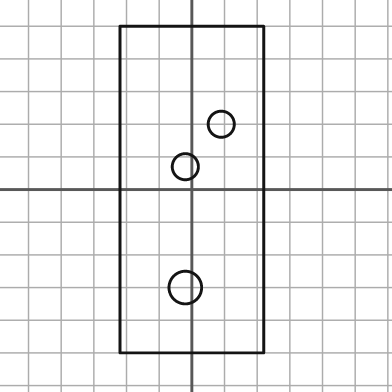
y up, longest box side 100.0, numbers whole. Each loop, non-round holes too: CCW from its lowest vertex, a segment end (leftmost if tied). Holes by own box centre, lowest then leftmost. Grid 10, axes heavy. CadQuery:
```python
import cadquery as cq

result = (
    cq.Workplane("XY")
    .moveTo(-22.0, -50.0)
    .lineTo(22.0, -50.0)
    .lineTo(22.0, 50.0)
    .lineTo(-22.0, 50.0)
    .close()
    .moveTo(-2.0, -30.0)
    .circle(5.0)
    .moveTo(-2.0, 7.0)
    .circle(4.0)
    .moveTo(9.0, 20.0)
    .circle(4.0)
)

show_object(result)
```